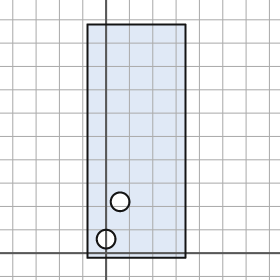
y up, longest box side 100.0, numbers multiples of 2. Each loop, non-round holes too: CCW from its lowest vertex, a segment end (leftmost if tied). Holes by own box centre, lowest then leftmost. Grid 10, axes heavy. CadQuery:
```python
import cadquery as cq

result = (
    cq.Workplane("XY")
    .moveTo(-8.0, -2.0)
    .lineTo(34.0, -2.0)
    .lineTo(34.0, 98.0)
    .lineTo(-8.0, 98.0)
    .close()
    .moveTo(0.0, 6.0)
    .circle(4.0)
    .moveTo(6.0, 22.0)
    .circle(4.0)
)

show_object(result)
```